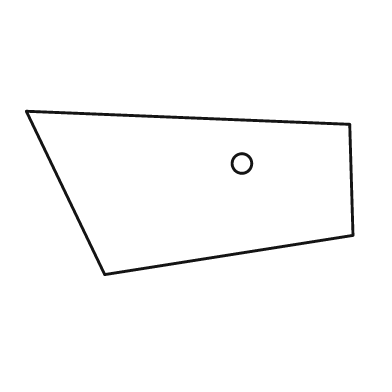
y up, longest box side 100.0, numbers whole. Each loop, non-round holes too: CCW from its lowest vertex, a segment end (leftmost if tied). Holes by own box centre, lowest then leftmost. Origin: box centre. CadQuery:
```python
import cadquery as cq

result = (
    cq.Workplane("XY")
    .moveTo(-26.0, -25.0)
    .lineTo(50.0, -13.0)
    .lineTo(49.0, 21.0)
    .lineTo(-50.0, 25.0)
    .close()
    .moveTo(16.0, 9.0)
    .circle(3.0)
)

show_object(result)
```